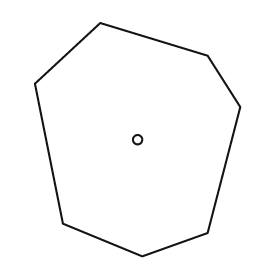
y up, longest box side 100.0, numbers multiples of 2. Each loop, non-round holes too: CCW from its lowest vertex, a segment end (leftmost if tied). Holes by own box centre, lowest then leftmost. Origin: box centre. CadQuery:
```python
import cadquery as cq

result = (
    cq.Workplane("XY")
    .moveTo(2.0, -50.0)
    .lineTo(30.0, -40.0)
    .lineTo(44.0, 14.0)
    .lineTo(30.0, 36.0)
    .lineTo(-16.0, 50.0)
    .lineTo(-44.0, 24.0)
    .lineTo(-32.0, -36.0)
    .close()
    .moveTo(0.0, 0.0)
    .circle(2.0)
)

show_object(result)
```